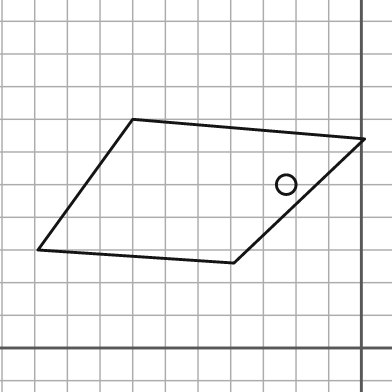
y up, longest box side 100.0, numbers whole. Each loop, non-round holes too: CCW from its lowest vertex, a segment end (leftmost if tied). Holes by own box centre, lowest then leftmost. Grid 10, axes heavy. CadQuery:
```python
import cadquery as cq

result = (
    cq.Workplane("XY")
    .moveTo(-39.0, 26.0)
    .lineTo(1.0, 64.0)
    .lineTo(-70.0, 70.0)
    .lineTo(-99.0, 30.0)
    .close()
    .moveTo(-23.0, 50.0)
    .circle(3.0)
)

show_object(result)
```